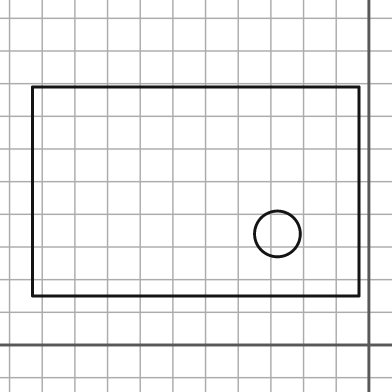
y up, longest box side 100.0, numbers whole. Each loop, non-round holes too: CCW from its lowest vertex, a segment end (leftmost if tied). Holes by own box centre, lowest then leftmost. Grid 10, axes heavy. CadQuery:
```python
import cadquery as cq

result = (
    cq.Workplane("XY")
    .moveTo(-103.0, 15.0)
    .lineTo(-3.0, 15.0)
    .lineTo(-3.0, 79.0)
    .lineTo(-103.0, 79.0)
    .close()
    .moveTo(-28.0, 34.0)
    .circle(7.0)
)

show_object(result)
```